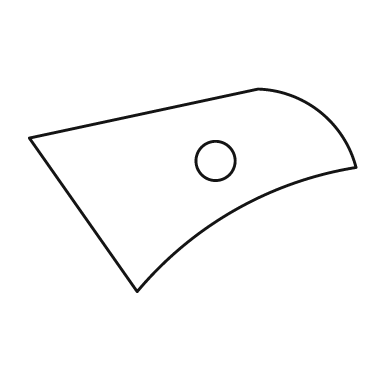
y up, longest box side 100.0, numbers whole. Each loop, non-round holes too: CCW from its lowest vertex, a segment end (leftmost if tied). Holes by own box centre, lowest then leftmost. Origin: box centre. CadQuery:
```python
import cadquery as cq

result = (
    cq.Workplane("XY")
    .moveTo(-17.0, -31.0)
    .threePointArc((13.0, -6.0), (50.0, 7.0))
    .threePointArc((39.0, 24.0), (20.0, 31.0))
    .lineTo(-50.0, 16.0)
    .close()
    .moveTo(7.0, 9.0)
    .circle(6.0)
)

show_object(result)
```